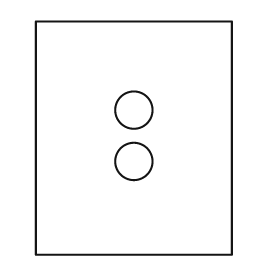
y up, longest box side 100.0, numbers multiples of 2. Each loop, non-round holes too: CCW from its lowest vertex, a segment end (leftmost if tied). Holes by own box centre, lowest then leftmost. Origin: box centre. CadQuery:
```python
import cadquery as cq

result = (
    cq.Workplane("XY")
    .moveTo(-42.0, -50.0)
    .lineTo(42.0, -50.0)
    .lineTo(42.0, 50.0)
    .lineTo(-42.0, 50.0)
    .close()
    .moveTo(0.0, -10.0)
    .circle(8.0)
    .moveTo(0.0, 12.0)
    .circle(8.0)
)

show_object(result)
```